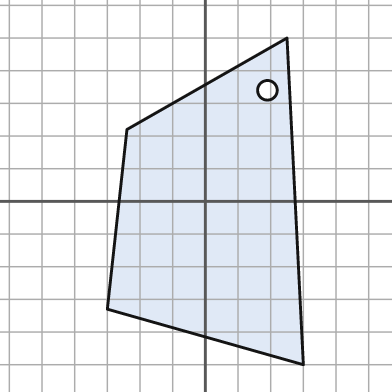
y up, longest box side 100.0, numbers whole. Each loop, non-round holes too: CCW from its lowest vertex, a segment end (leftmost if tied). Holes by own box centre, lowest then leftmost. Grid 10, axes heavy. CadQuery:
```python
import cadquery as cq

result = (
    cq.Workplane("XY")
    .moveTo(30.0, -50.0)
    .lineTo(25.0, 50.0)
    .lineTo(-24.0, 22.0)
    .lineTo(-30.0, -33.0)
    .close()
    .moveTo(19.0, 34.0)
    .circle(3.0)
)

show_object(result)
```